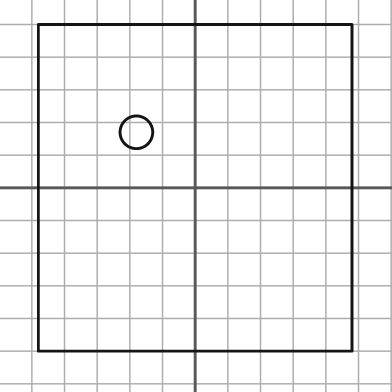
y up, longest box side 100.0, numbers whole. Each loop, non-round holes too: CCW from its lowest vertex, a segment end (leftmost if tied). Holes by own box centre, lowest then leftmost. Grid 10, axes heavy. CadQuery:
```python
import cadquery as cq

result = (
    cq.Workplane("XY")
    .moveTo(-48.0, -50.0)
    .lineTo(48.0, -50.0)
    .lineTo(48.0, 50.0)
    .lineTo(-48.0, 50.0)
    .close()
    .moveTo(-18.0, 17.0)
    .circle(5.0)
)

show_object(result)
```